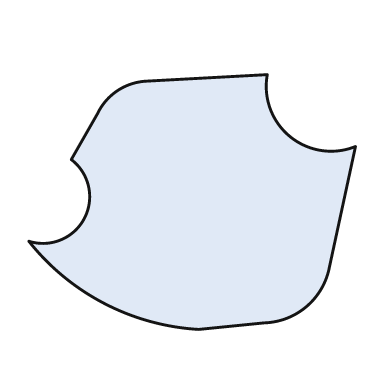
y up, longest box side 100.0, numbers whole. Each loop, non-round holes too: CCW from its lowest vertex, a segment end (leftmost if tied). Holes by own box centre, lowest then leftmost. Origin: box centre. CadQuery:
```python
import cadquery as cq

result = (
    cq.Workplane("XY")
    .moveTo(2.0, -39.0)
    .lineTo(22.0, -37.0)
    .threePointArc((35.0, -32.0), (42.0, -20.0))
    .lineTo(50.0, 17.0)
    .threePointArc((30.0, 20.0), (23.0, 39.0))
    .lineTo(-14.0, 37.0)
    .threePointArc((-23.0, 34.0), (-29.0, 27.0))
    .lineTo(-37.0, 13.0)
    .threePointArc((-33.0, -5.0), (-50.0, -12.0))
    .threePointArc((-27.0, -31.0), (2.0, -39.0))
    .close()
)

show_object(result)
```